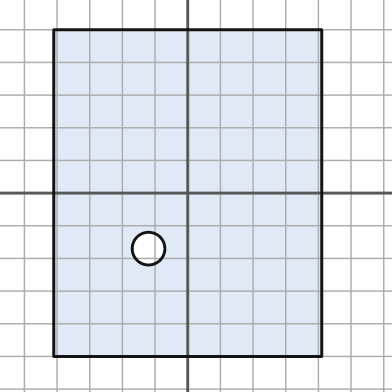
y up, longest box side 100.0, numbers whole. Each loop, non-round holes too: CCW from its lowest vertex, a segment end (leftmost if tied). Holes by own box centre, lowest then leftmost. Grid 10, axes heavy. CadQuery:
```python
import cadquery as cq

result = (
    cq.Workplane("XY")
    .moveTo(-41.0, -50.0)
    .lineTo(41.0, -50.0)
    .lineTo(41.0, 50.0)
    .lineTo(-41.0, 50.0)
    .close()
    .moveTo(-12.0, -17.0)
    .circle(5.0)
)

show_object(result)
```